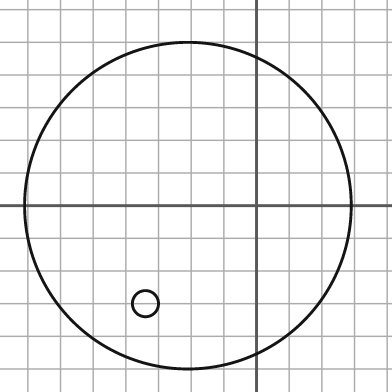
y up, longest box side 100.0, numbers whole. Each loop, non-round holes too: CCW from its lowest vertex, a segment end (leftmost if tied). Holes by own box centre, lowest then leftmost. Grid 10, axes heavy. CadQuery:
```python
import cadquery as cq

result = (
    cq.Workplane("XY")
    .moveTo(-21.0, 0.0)
    .circle(50.0)
    .moveTo(-34.0, -30.0)
    .circle(4.0)
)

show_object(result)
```